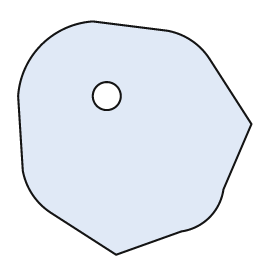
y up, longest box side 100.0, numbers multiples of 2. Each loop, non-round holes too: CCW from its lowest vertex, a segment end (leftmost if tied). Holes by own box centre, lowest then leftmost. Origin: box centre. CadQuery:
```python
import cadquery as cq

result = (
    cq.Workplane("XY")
    .moveTo(-8.0, -50.0)
    .lineTo(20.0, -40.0)
    .threePointArc((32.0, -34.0), (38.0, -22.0))
    .lineTo(50.0, 6.0)
    .lineTo(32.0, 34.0)
    .threePointArc((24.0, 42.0), (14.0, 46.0))
    .lineTo(-18.0, 50.0)
    .threePointArc((-40.0, 40.0), (-50.0, 18.0))
    .lineTo(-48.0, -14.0)
    .threePointArc((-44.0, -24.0), (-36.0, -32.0))
    .close()
    .moveTo(-12.0, 18.0)
    .circle(6.0)
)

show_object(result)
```